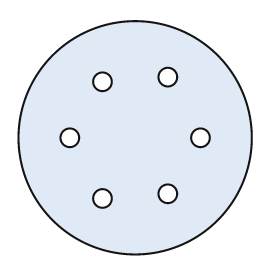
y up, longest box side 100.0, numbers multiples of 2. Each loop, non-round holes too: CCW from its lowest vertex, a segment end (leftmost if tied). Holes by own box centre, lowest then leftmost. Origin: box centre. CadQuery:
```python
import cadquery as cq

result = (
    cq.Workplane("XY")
    .moveTo(0.0, 0.0)
    .circle(50.0)
    .moveTo(-14.0, -26.0)
    .circle(4.0)
    .moveTo(14.0, -24.0)
    .circle(4.0)
    .moveTo(-28.0, 0.0)
    .circle(4.0)
    .moveTo(28.0, 0.0)
    .circle(4.0)
    .moveTo(-14.0, 24.0)
    .circle(4.0)
    .moveTo(14.0, 26.0)
    .circle(4.0)
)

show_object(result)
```